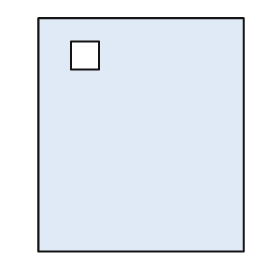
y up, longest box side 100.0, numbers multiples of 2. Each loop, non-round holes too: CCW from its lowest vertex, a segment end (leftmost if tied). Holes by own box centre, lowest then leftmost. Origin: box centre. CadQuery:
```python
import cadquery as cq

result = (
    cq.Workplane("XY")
    .moveTo(-44.0, -50.0)
    .lineTo(44.0, -50.0)
    .lineTo(44.0, 50.0)
    .lineTo(-44.0, 50.0)
    .close()
    .moveTo(-30.0, 28.0)
    .lineTo(-18.0, 28.0)
    .lineTo(-18.0, 40.0)
    .lineTo(-30.0, 40.0)
    .close()
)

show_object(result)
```